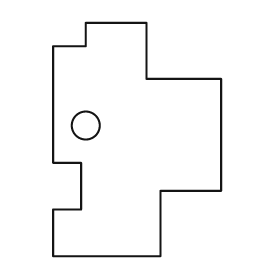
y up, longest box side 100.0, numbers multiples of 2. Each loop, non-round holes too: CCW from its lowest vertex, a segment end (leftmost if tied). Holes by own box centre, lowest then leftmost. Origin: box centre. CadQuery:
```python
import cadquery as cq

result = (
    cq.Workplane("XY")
    .moveTo(-36.0, -50.0)
    .lineTo(10.0, -50.0)
    .lineTo(10.0, -22.0)
    .lineTo(36.0, -22.0)
    .lineTo(36.0, 26.0)
    .lineTo(4.0, 26.0)
    .lineTo(4.0, 50.0)
    .lineTo(-22.0, 50.0)
    .lineTo(-22.0, 40.0)
    .lineTo(-36.0, 40.0)
    .lineTo(-36.0, -10.0)
    .lineTo(-24.0, -10.0)
    .lineTo(-24.0, -30.0)
    .lineTo(-36.0, -30.0)
    .close()
    .moveTo(-22.0, 6.0)
    .circle(6.0)
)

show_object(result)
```